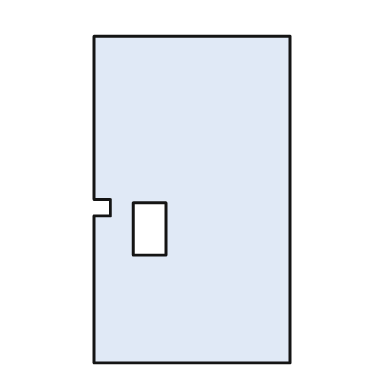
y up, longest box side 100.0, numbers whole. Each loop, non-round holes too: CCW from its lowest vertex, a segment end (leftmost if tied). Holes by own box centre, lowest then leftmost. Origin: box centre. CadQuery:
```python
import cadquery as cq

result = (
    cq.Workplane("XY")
    .moveTo(-30.0, -50.0)
    .lineTo(30.0, -50.0)
    .lineTo(30.0, 50.0)
    .lineTo(-30.0, 50.0)
    .lineTo(-30.0, 0.0)
    .lineTo(-25.0, 0.0)
    .lineTo(-25.0, -5.0)
    .lineTo(-30.0, -5.0)
    .close()
    .moveTo(-18.0, -17.0)
    .lineTo(-8.0, -17.0)
    .lineTo(-8.0, -1.0)
    .lineTo(-18.0, -1.0)
    .close()
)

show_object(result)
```